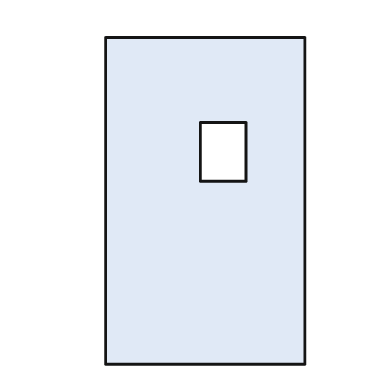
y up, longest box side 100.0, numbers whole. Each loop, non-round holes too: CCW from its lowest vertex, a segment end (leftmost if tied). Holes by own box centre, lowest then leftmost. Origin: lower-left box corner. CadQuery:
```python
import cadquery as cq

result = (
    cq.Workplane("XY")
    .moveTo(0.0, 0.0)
    .lineTo(61.0, 0.0)
    .lineTo(61.0, 100.0)
    .lineTo(0.0, 100.0)
    .close()
    .moveTo(29.0, 56.0)
    .lineTo(43.0, 56.0)
    .lineTo(43.0, 74.0)
    .lineTo(29.0, 74.0)
    .close()
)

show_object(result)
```